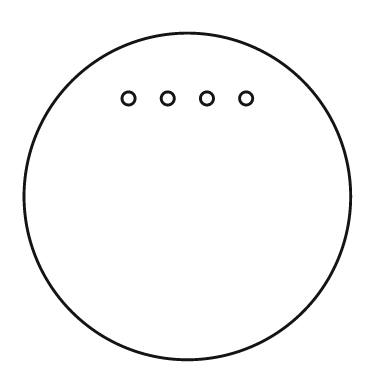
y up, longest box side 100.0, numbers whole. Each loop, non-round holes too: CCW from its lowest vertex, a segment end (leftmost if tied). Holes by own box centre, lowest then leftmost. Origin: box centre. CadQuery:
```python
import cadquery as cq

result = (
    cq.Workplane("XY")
    .moveTo(0.0, 0.0)
    .circle(50.0)
    .moveTo(-18.0, 30.0)
    .circle(2.0)
    .moveTo(-6.0, 30.0)
    .circle(2.0)
    .moveTo(6.0, 30.0)
    .circle(2.0)
    .moveTo(18.0, 30.0)
    .circle(2.0)
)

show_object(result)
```